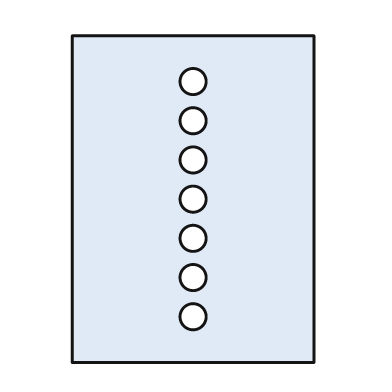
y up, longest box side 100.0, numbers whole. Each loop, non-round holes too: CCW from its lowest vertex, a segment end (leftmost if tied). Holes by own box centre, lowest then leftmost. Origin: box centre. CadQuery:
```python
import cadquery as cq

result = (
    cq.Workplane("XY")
    .moveTo(-37.0, -50.0)
    .lineTo(37.0, -50.0)
    .lineTo(37.0, 50.0)
    .lineTo(-37.0, 50.0)
    .close()
    .moveTo(0.0, -36.0)
    .circle(4.0)
    .moveTo(0.0, -24.0)
    .circle(4.0)
    .moveTo(0.0, -12.0)
    .circle(4.0)
    .moveTo(0.0, 0.0)
    .circle(4.0)
    .moveTo(0.0, 12.0)
    .circle(4.0)
    .moveTo(0.0, 24.0)
    .circle(4.0)
    .moveTo(0.0, 36.0)
    .circle(4.0)
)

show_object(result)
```